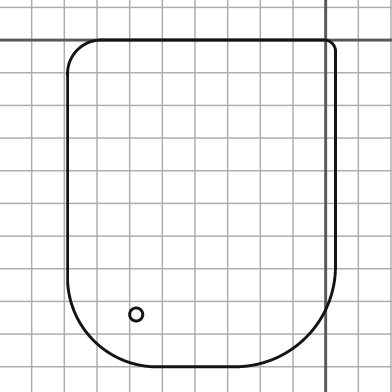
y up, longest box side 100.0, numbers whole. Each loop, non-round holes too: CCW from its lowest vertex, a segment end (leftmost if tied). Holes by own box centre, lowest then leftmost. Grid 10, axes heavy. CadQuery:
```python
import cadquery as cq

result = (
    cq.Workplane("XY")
    .moveTo(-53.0, -100.0)
    .lineTo(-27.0, -100.0)
    .threePointArc((-6.0, -91.0), (3.0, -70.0))
    .lineTo(3.0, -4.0)
    .threePointArc((2.0, -1.0), (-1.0, 0.0))
    .lineTo(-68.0, 0.0)
    .threePointArc((-76.0, -3.0), (-79.0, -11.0))
    .lineTo(-79.0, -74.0)
    .threePointArc((-71.0, -92.0), (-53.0, -100.0))
    .close()
    .moveTo(-58.0, -84.0)
    .circle(2.0)
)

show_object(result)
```